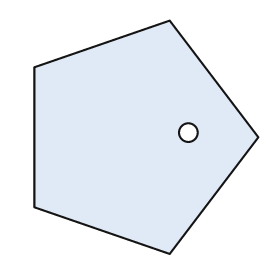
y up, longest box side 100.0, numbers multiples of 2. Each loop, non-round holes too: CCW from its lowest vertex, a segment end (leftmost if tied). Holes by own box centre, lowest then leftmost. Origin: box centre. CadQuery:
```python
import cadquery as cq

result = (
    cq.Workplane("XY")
    .moveTo(10.0, -50.0)
    .lineTo(48.0, 0.0)
    .lineTo(10.0, 50.0)
    .lineTo(-48.0, 30.0)
    .lineTo(-48.0, -30.0)
    .close()
    .moveTo(18.0, 2.0)
    .circle(4.0)
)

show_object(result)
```